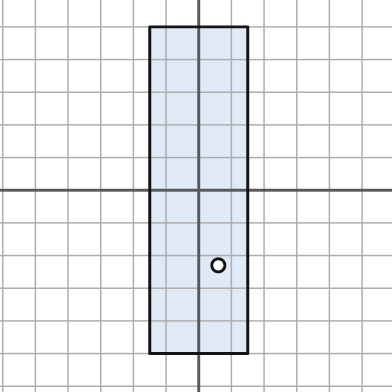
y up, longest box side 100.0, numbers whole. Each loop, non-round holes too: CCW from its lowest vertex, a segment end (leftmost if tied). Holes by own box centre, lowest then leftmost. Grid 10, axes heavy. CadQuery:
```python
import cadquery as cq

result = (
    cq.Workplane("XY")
    .moveTo(-15.0, -50.0)
    .lineTo(15.0, -50.0)
    .lineTo(15.0, 50.0)
    .lineTo(-15.0, 50.0)
    .close()
    .moveTo(6.0, -23.0)
    .circle(2.0)
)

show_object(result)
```